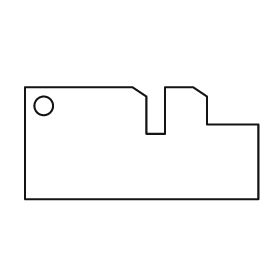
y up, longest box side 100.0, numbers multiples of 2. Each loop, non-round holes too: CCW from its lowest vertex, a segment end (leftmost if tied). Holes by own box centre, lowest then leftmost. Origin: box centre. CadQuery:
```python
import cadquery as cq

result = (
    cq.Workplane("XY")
    .moveTo(-50.0, -24.0)
    .lineTo(50.0, -24.0)
    .lineTo(50.0, 8.0)
    .lineTo(28.0, 8.0)
    .lineTo(28.0, 20.0)
    .lineTo(22.0, 24.0)
    .lineTo(10.0, 24.0)
    .lineTo(10.0, 4.0)
    .lineTo(2.0, 4.0)
    .lineTo(2.0, 20.0)
    .lineTo(-4.0, 24.0)
    .lineTo(-50.0, 24.0)
    .close()
    .moveTo(-42.0, 16.0)
    .circle(4.0)
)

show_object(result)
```